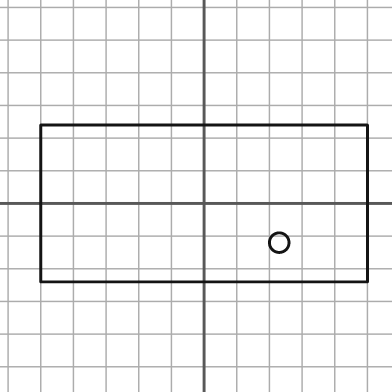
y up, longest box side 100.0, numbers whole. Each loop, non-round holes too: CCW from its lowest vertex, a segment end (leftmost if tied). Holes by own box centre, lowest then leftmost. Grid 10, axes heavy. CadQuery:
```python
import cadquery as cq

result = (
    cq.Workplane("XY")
    .moveTo(-50.0, -24.0)
    .lineTo(50.0, -24.0)
    .lineTo(50.0, 24.0)
    .lineTo(-50.0, 24.0)
    .close()
    .moveTo(23.0, -12.0)
    .circle(3.0)
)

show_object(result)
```